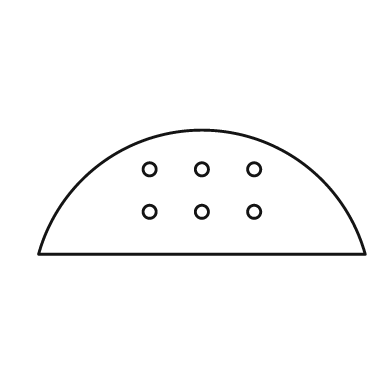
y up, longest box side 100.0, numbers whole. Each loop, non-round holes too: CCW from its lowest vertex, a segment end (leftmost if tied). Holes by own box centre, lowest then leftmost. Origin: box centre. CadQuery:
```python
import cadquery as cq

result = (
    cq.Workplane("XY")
    .moveTo(-50.0, -19.0)
    .lineTo(50.0, -19.0)
    .threePointArc((0.0, 19.0), (-50.0, -19.0))
    .close()
    .moveTo(-16.0, -6.0)
    .circle(2.0)
    .moveTo(0.0, -6.0)
    .circle(2.0)
    .moveTo(16.0, -6.0)
    .circle(2.0)
    .moveTo(-16.0, 7.0)
    .circle(2.0)
    .moveTo(0.0, 7.0)
    .circle(2.0)
    .moveTo(16.0, 7.0)
    .circle(2.0)
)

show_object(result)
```